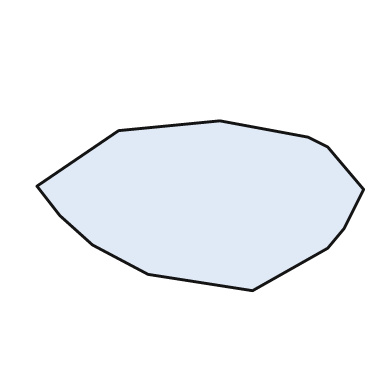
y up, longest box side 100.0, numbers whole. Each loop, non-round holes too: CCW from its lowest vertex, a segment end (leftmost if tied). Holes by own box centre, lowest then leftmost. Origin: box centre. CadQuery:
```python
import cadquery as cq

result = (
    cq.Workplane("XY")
    .moveTo(16.0, -26.0)
    .lineTo(39.0, -13.0)
    .lineTo(44.0, -7.0)
    .lineTo(50.0, 5.0)
    .lineTo(39.0, 18.0)
    .lineTo(33.0, 21.0)
    .lineTo(6.0, 26.0)
    .lineTo(-25.0, 23.0)
    .lineTo(-50.0, 6.0)
    .lineTo(-43.0, -3.0)
    .lineTo(-33.0, -12.0)
    .lineTo(-16.0, -21.0)
    .close()
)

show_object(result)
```